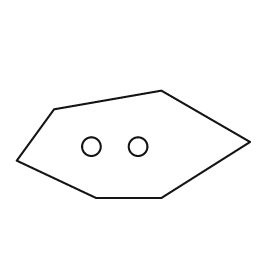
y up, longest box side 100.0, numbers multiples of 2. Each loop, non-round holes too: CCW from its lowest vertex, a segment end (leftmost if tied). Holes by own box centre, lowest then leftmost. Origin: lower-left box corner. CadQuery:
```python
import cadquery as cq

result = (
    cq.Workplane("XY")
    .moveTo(34.0, 0.0)
    .lineTo(62.0, 0.0)
    .lineTo(100.0, 24.0)
    .lineTo(62.0, 46.0)
    .lineTo(16.0, 38.0)
    .lineTo(0.0, 16.0)
    .close()
    .moveTo(32.0, 22.0)
    .circle(4.0)
    .moveTo(52.0, 22.0)
    .circle(4.0)
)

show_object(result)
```